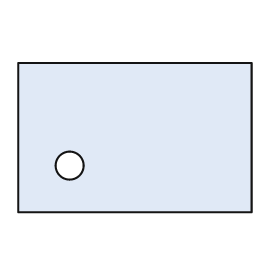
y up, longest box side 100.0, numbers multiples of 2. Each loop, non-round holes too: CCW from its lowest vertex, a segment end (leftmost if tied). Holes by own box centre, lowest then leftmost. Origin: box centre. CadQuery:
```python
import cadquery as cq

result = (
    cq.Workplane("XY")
    .moveTo(-50.0, -32.0)
    .lineTo(50.0, -32.0)
    .lineTo(50.0, 32.0)
    .lineTo(-50.0, 32.0)
    .close()
    .moveTo(-28.0, -12.0)
    .circle(6.0)
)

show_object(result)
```